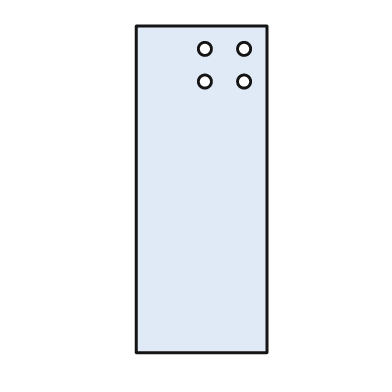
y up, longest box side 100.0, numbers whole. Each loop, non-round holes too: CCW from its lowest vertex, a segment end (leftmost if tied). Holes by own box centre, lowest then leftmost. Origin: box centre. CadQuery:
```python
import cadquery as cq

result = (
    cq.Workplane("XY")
    .moveTo(-20.0, -50.0)
    .lineTo(20.0, -50.0)
    .lineTo(20.0, 50.0)
    .lineTo(-20.0, 50.0)
    .close()
    .moveTo(1.0, 33.0)
    .circle(2.0)
    .moveTo(13.0, 33.0)
    .circle(2.0)
    .moveTo(1.0, 43.0)
    .circle(2.0)
    .moveTo(13.0, 43.0)
    .circle(2.0)
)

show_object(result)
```